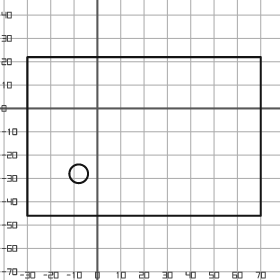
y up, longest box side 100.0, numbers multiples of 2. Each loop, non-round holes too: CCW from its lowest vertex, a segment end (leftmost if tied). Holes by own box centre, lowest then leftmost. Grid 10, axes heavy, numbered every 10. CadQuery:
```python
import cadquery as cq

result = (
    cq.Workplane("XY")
    .moveTo(-30.0, -46.0)
    .lineTo(70.0, -46.0)
    .lineTo(70.0, 22.0)
    .lineTo(-30.0, 22.0)
    .close()
    .moveTo(-8.0, -28.0)
    .circle(4.0)
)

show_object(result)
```